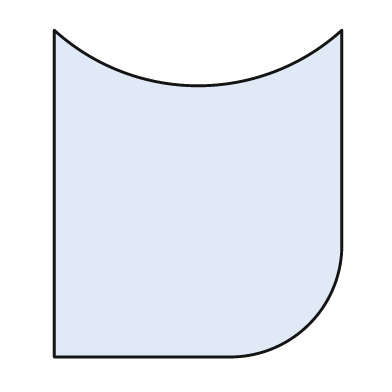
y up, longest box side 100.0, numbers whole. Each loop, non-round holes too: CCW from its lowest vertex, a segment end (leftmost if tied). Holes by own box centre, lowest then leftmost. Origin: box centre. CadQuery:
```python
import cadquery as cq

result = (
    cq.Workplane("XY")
    .moveTo(-44.0, -50.0)
    .lineTo(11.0, -50.0)
    .threePointArc((34.0, -40.0), (44.0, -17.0))
    .lineTo(44.0, 50.0)
    .threePointArc((0.0, 33.0), (-44.0, 50.0))
    .close()
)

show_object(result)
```